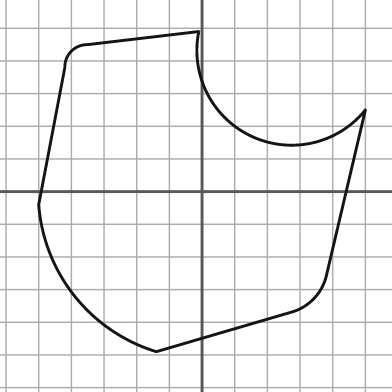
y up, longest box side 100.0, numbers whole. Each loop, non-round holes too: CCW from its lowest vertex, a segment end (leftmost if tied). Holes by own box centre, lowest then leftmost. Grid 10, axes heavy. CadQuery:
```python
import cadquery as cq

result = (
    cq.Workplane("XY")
    .moveTo(-14.0, -49.0)
    .lineTo(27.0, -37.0)
    .threePointArc((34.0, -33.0), (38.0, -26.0))
    .lineTo(50.0, 25.0)
    .threePointArc((15.0, 17.0), (-1.0, 49.0))
    .lineTo(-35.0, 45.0)
    .threePointArc((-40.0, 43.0), (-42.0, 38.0))
    .lineTo(-50.0, -4.0)
    .threePointArc((-39.0, -32.0), (-14.0, -49.0))
    .close()
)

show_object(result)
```